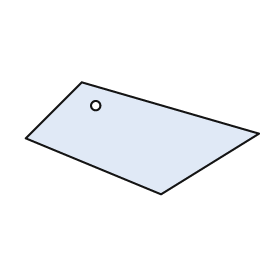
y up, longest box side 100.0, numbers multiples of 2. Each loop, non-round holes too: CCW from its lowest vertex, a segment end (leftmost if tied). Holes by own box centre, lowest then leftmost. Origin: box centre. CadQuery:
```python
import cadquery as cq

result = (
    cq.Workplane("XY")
    .moveTo(8.0, -24.0)
    .lineTo(50.0, 2.0)
    .lineTo(-26.0, 24.0)
    .lineTo(-50.0, 0.0)
    .close()
    .moveTo(-20.0, 14.0)
    .circle(2.0)
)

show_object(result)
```